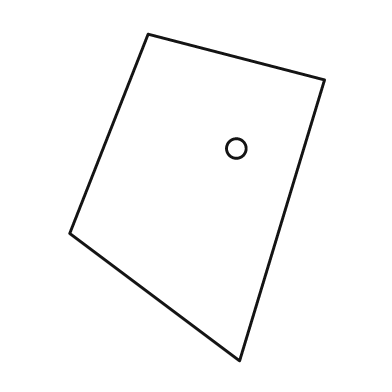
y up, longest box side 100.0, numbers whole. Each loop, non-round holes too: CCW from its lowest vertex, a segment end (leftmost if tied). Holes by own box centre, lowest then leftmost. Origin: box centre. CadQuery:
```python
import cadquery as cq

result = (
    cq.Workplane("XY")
    .moveTo(13.0, -50.0)
    .lineTo(39.0, 36.0)
    .lineTo(-15.0, 50.0)
    .lineTo(-39.0, -11.0)
    .close()
    .moveTo(12.0, 15.0)
    .circle(3.0)
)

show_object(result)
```